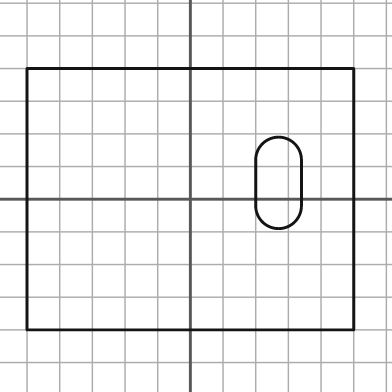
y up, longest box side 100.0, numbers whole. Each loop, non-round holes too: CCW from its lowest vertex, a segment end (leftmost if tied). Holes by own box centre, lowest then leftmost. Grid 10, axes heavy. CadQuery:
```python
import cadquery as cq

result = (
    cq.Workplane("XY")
    .moveTo(-50.0, -40.0)
    .lineTo(50.0, -40.0)
    .lineTo(50.0, 40.0)
    .lineTo(-50.0, 40.0)
    .close()
    .moveTo(20.0, -2.0)
    .threePointArc((27.0, -9.0), (34.0, -2.0))
    .lineTo(34.0, 12.0)
    .threePointArc((27.0, 19.0), (20.0, 12.0))
    .close()
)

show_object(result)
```